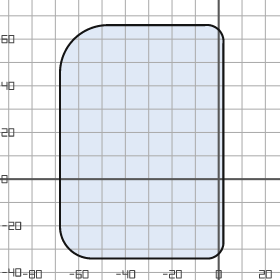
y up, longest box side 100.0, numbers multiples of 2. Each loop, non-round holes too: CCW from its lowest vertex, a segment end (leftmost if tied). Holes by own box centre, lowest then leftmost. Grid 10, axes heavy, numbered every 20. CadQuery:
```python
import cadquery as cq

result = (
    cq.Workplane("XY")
    .moveTo(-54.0, -34.0)
    .lineTo(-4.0, -34.0)
    .threePointArc((0.0, -32.0), (2.0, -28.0))
    .lineTo(2.0, 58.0)
    .threePointArc((0.0, 64.0), (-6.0, 66.0))
    .lineTo(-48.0, 66.0)
    .threePointArc((-62.0, 60.0), (-68.0, 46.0))
    .lineTo(-68.0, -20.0)
    .threePointArc((-64.0, -30.0), (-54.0, -34.0))
    .close()
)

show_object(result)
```